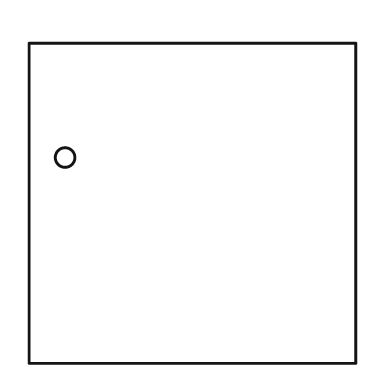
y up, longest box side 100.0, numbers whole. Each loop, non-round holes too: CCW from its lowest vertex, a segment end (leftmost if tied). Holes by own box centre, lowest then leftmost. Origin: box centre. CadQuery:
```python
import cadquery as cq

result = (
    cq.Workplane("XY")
    .moveTo(-50.0, -49.0)
    .lineTo(50.0, -49.0)
    .lineTo(50.0, 49.0)
    .lineTo(-50.0, 49.0)
    .close()
    .moveTo(-39.0, 14.0)
    .circle(3.0)
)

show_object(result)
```